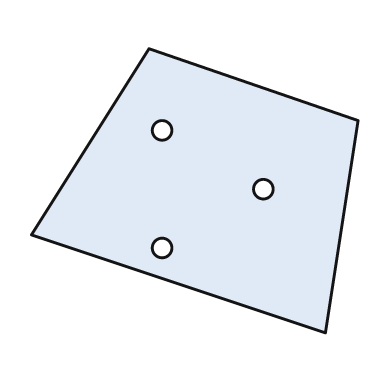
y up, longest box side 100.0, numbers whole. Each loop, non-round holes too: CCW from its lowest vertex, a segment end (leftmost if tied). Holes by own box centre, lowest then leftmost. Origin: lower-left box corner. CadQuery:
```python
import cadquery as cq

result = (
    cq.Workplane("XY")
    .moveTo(90.0, 0.0)
    .lineTo(100.0, 65.0)
    .lineTo(36.0, 87.0)
    .lineTo(0.0, 30.0)
    .close()
    .moveTo(40.0, 26.0)
    .circle(3.0)
    .moveTo(71.0, 44.0)
    .circle(3.0)
    .moveTo(40.0, 62.0)
    .circle(3.0)
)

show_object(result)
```